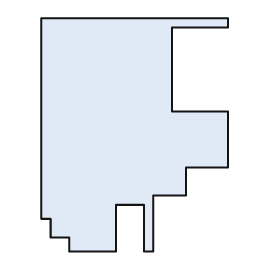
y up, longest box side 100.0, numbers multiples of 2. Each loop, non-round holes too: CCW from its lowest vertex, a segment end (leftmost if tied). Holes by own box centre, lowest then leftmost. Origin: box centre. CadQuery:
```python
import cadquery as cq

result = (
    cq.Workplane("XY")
    .moveTo(-28.0, -50.0)
    .lineTo(-8.0, -50.0)
    .lineTo(-8.0, -30.0)
    .lineTo(4.0, -30.0)
    .lineTo(4.0, -50.0)
    .lineTo(8.0, -50.0)
    .lineTo(8.0, -26.0)
    .lineTo(22.0, -26.0)
    .lineTo(22.0, -14.0)
    .lineTo(40.0, -14.0)
    .lineTo(40.0, 10.0)
    .lineTo(16.0, 10.0)
    .lineTo(16.0, 46.0)
    .lineTo(40.0, 46.0)
    .lineTo(40.0, 50.0)
    .lineTo(-40.0, 50.0)
    .lineTo(-40.0, -36.0)
    .lineTo(-36.0, -36.0)
    .lineTo(-36.0, -44.0)
    .lineTo(-28.0, -44.0)
    .close()
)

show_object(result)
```